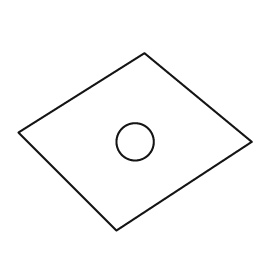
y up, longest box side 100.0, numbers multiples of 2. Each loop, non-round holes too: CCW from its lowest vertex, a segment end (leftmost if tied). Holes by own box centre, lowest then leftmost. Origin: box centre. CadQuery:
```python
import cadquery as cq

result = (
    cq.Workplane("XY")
    .moveTo(-8.0, -38.0)
    .lineTo(50.0, 0.0)
    .lineTo(4.0, 38.0)
    .lineTo(-50.0, 4.0)
    .close()
    .moveTo(0.0, 0.0)
    .circle(8.0)
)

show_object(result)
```